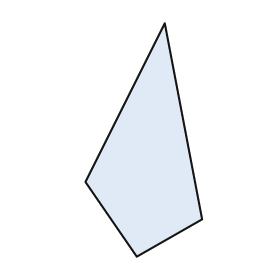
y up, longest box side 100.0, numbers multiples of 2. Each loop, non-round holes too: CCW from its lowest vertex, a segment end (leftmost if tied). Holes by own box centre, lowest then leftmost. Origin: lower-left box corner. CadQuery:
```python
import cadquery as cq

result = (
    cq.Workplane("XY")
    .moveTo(22.0, 0.0)
    .lineTo(50.0, 16.0)
    .lineTo(34.0, 100.0)
    .lineTo(0.0, 32.0)
    .close()
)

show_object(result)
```